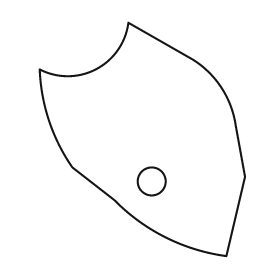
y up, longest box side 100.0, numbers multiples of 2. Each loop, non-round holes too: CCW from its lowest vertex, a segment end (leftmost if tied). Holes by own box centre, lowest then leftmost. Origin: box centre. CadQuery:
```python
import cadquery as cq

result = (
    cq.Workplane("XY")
    .moveTo(36.0, -50.0)
    .lineTo(44.0, -16.0)
    .lineTo(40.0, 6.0)
    .threePointArc((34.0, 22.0), (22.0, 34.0))
    .lineTo(-6.0, 50.0)
    .threePointArc((-20.0, 30.0), (-44.0, 30.0))
    .threePointArc((-40.0, 8.0), (-30.0, -12.0))
    .lineTo(-12.0, -26.0)
    .threePointArc((10.0, -42.0), (36.0, -50.0))
    .close()
    .moveTo(4.0, -18.0)
    .circle(6.0)
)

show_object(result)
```